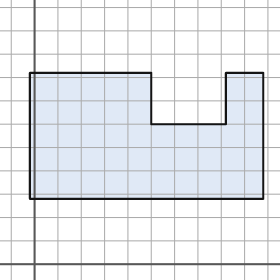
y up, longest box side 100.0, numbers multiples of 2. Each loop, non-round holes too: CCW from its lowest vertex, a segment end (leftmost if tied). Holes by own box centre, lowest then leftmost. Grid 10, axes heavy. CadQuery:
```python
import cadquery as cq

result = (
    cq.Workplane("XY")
    .moveTo(-2.0, 28.0)
    .lineTo(98.0, 28.0)
    .lineTo(98.0, 82.0)
    .lineTo(82.0, 82.0)
    .lineTo(82.0, 60.0)
    .lineTo(50.0, 60.0)
    .lineTo(50.0, 82.0)
    .lineTo(-2.0, 82.0)
    .close()
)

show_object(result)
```